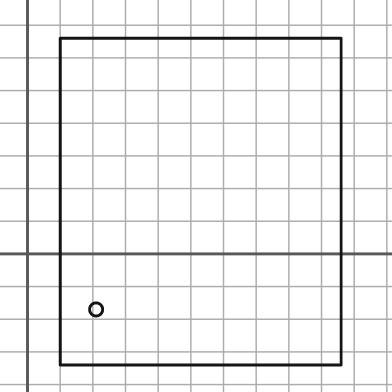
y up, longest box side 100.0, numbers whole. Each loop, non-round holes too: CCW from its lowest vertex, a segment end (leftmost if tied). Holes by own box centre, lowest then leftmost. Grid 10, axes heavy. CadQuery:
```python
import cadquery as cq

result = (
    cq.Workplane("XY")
    .moveTo(10.0, -34.0)
    .lineTo(96.0, -34.0)
    .lineTo(96.0, 66.0)
    .lineTo(10.0, 66.0)
    .close()
    .moveTo(21.0, -17.0)
    .circle(2.0)
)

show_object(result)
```